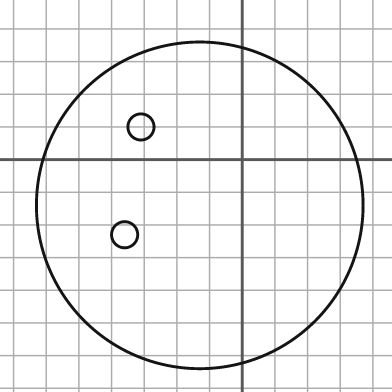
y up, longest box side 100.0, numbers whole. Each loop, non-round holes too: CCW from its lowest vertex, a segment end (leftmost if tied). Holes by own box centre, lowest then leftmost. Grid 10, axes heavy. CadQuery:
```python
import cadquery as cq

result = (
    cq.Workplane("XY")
    .moveTo(-13.0, -14.0)
    .circle(50.0)
    .moveTo(-36.0, -23.0)
    .circle(4.0)
    .moveTo(-31.0, 10.0)
    .circle(4.0)
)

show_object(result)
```